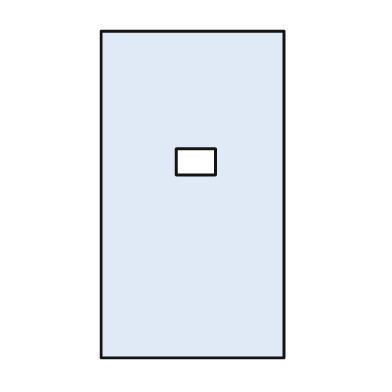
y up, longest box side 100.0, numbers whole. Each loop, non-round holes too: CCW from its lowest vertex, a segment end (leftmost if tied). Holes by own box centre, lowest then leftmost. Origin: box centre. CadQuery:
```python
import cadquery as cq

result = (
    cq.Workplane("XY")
    .moveTo(-28.0, -50.0)
    .lineTo(28.0, -50.0)
    .lineTo(28.0, 50.0)
    .lineTo(-28.0, 50.0)
    .close()
    .moveTo(-5.0, 6.0)
    .lineTo(7.0, 6.0)
    .lineTo(7.0, 14.0)
    .lineTo(-5.0, 14.0)
    .close()
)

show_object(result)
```